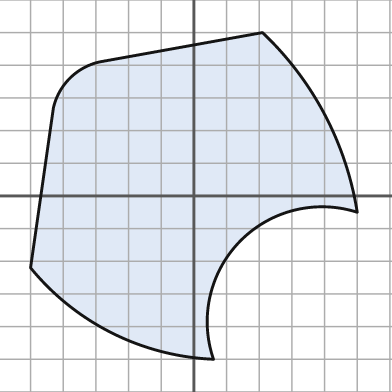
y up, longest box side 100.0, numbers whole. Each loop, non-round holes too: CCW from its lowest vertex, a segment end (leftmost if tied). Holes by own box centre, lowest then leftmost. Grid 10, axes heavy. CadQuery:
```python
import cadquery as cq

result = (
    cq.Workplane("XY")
    .moveTo(6.0, -50.0)
    .threePointArc((14.0, -14.0), (50.0, -5.0))
    .threePointArc((40.0, 25.0), (21.0, 50.0))
    .lineTo(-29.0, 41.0)
    .threePointArc((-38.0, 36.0), (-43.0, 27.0))
    .lineTo(-50.0, -22.0)
    .threePointArc((-25.0, -42.0), (6.0, -50.0))
    .close()
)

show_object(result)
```